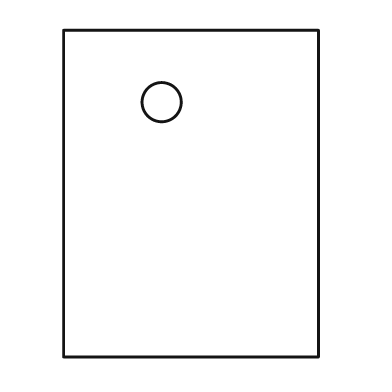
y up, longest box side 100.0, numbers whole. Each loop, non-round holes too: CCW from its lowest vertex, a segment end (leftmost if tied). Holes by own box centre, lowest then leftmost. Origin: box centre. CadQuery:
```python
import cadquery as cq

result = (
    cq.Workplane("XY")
    .moveTo(-39.0, -50.0)
    .lineTo(39.0, -50.0)
    .lineTo(39.0, 50.0)
    .lineTo(-39.0, 50.0)
    .close()
    .moveTo(-9.0, 28.0)
    .circle(6.0)
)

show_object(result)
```